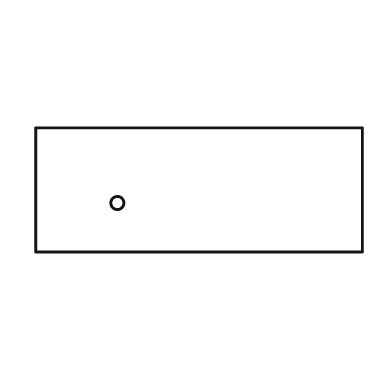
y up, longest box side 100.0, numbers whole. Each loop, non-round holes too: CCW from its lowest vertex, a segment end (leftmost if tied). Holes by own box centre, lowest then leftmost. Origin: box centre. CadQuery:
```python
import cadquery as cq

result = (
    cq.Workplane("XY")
    .moveTo(-50.0, -19.0)
    .lineTo(50.0, -19.0)
    .lineTo(50.0, 19.0)
    .lineTo(-50.0, 19.0)
    .close()
    .moveTo(-25.0, -4.0)
    .circle(2.0)
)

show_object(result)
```